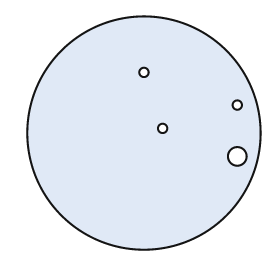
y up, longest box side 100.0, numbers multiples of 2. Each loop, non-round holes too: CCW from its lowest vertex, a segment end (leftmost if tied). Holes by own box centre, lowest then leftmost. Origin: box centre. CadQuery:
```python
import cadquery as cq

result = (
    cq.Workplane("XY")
    .moveTo(0.0, 0.0)
    .circle(50.0)
    .moveTo(40.0, -10.0)
    .circle(4.0)
    .moveTo(8.0, 2.0)
    .circle(2.0)
    .moveTo(40.0, 12.0)
    .circle(2.0)
    .moveTo(0.0, 26.0)
    .circle(2.0)
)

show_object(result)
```